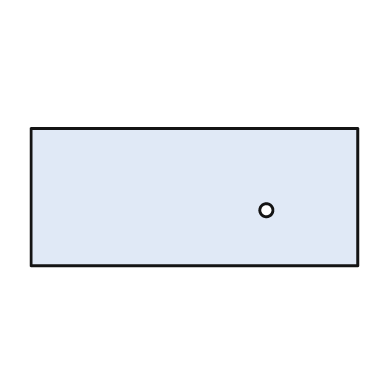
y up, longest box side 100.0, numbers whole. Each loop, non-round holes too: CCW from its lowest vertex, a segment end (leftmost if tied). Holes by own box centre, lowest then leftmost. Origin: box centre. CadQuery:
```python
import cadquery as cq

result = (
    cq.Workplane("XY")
    .moveTo(-50.0, -21.0)
    .lineTo(50.0, -21.0)
    .lineTo(50.0, 21.0)
    .lineTo(-50.0, 21.0)
    .close()
    .moveTo(22.0, -4.0)
    .circle(2.0)
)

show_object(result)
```